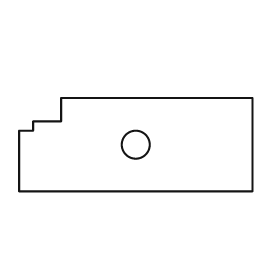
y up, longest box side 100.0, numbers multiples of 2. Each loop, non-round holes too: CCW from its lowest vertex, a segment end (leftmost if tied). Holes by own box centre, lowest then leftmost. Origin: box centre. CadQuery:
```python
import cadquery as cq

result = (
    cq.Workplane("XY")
    .moveTo(-50.0, -20.0)
    .lineTo(50.0, -20.0)
    .lineTo(50.0, 20.0)
    .lineTo(-32.0, 20.0)
    .lineTo(-32.0, 10.0)
    .lineTo(-44.0, 10.0)
    .lineTo(-44.0, 6.0)
    .lineTo(-50.0, 6.0)
    .close()
    .moveTo(0.0, 0.0)
    .circle(6.0)
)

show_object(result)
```